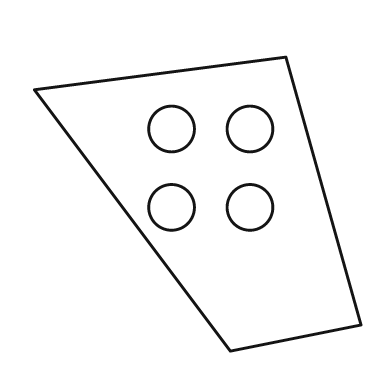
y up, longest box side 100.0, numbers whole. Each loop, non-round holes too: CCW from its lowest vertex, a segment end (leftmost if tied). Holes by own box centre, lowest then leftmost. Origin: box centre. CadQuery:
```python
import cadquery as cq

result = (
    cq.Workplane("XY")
    .moveTo(10.0, -45.0)
    .lineTo(50.0, -37.0)
    .lineTo(27.0, 45.0)
    .lineTo(-50.0, 35.0)
    .close()
    .moveTo(-8.0, -1.0)
    .circle(7.0)
    .moveTo(16.0, -1.0)
    .circle(7.0)
    .moveTo(-8.0, 23.0)
    .circle(7.0)
    .moveTo(16.0, 23.0)
    .circle(7.0)
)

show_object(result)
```